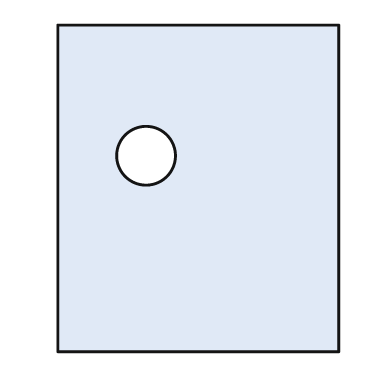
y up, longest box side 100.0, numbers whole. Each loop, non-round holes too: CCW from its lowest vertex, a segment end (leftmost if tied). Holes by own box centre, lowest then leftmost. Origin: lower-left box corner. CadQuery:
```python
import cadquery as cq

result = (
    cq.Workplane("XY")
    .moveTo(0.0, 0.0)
    .lineTo(86.0, 0.0)
    .lineTo(86.0, 100.0)
    .lineTo(0.0, 100.0)
    .close()
    .moveTo(27.0, 60.0)
    .circle(9.0)
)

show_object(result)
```